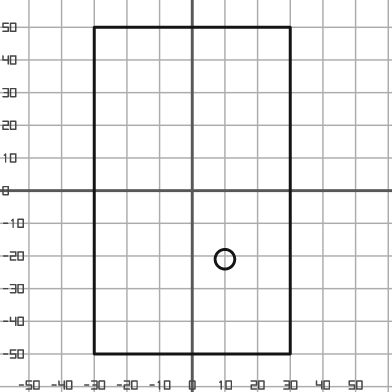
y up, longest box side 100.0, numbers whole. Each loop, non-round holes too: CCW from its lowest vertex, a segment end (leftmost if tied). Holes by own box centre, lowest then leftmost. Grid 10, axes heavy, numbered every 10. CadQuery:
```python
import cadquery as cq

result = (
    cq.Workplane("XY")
    .moveTo(-30.0, -50.0)
    .lineTo(30.0, -50.0)
    .lineTo(30.0, 50.0)
    .lineTo(-30.0, 50.0)
    .close()
    .moveTo(10.0, -21.0)
    .circle(3.0)
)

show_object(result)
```